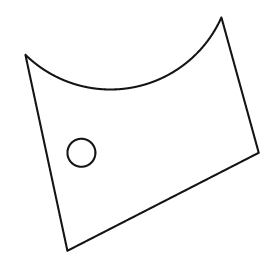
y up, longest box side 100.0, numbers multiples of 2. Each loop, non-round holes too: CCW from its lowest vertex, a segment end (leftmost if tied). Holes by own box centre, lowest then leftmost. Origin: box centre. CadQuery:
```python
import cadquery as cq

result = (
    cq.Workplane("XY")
    .moveTo(-32.0, -50.0)
    .lineTo(50.0, -8.0)
    .lineTo(34.0, 50.0)
    .threePointArc((-4.0, 20.0), (-50.0, 34.0))
    .close()
    .moveTo(-26.0, -8.0)
    .circle(6.0)
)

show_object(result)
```